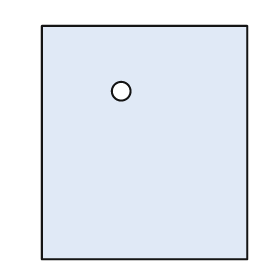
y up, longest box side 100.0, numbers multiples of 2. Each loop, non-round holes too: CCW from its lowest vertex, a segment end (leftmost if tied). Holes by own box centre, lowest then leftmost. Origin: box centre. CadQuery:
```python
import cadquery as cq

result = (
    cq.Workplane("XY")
    .moveTo(-44.0, -50.0)
    .lineTo(44.0, -50.0)
    .lineTo(44.0, 50.0)
    .lineTo(-44.0, 50.0)
    .close()
    .moveTo(-10.0, 22.0)
    .circle(4.0)
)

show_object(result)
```